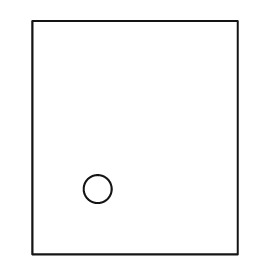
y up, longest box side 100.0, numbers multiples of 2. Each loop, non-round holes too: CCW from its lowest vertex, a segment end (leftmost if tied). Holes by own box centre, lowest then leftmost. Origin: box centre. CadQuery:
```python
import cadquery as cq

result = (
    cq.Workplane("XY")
    .moveTo(-44.0, -50.0)
    .lineTo(44.0, -50.0)
    .lineTo(44.0, 50.0)
    .lineTo(-44.0, 50.0)
    .close()
    .moveTo(-16.0, -22.0)
    .circle(6.0)
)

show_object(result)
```